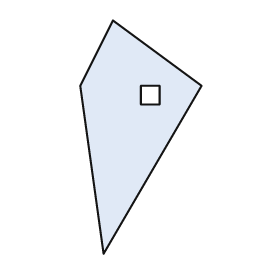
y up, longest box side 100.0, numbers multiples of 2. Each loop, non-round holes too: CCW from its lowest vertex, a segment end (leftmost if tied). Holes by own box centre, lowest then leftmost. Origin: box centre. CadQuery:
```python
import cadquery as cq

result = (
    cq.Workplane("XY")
    .moveTo(-16.0, -50.0)
    .lineTo(26.0, 22.0)
    .lineTo(-12.0, 50.0)
    .lineTo(-26.0, 22.0)
    .close()
    .moveTo(0.0, 14.0)
    .lineTo(8.0, 14.0)
    .lineTo(8.0, 22.0)
    .lineTo(0.0, 22.0)
    .close()
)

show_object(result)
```